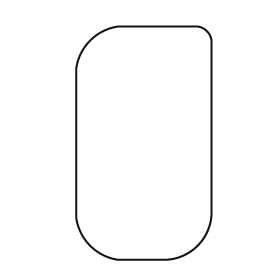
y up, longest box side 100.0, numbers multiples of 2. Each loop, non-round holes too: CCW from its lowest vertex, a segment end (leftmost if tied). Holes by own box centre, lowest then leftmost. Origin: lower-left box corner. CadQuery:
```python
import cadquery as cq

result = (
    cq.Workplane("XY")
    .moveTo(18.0, 0.0)
    .lineTo(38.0, 0.0)
    .threePointArc((52.0, 6.0), (58.0, 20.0))
    .lineTo(58.0, 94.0)
    .threePointArc((56.0, 98.0), (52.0, 100.0))
    .lineTo(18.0, 100.0)
    .threePointArc((6.0, 94.0), (0.0, 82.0))
    .lineTo(0.0, 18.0)
    .threePointArc((6.0, 6.0), (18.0, 0.0))
    .close()
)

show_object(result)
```